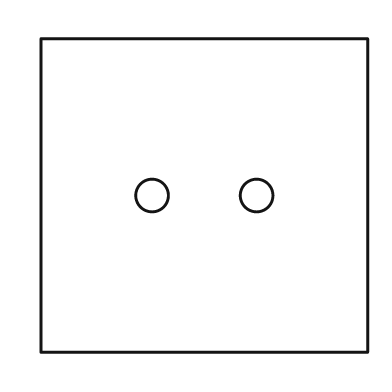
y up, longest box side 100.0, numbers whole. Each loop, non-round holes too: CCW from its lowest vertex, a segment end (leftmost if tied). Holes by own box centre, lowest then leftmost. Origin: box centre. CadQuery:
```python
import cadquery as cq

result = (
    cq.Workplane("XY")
    .moveTo(-50.0, -48.0)
    .lineTo(50.0, -48.0)
    .lineTo(50.0, 48.0)
    .lineTo(-50.0, 48.0)
    .close()
    .moveTo(-16.0, 0.0)
    .circle(5.0)
    .moveTo(16.0, 0.0)
    .circle(5.0)
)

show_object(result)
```